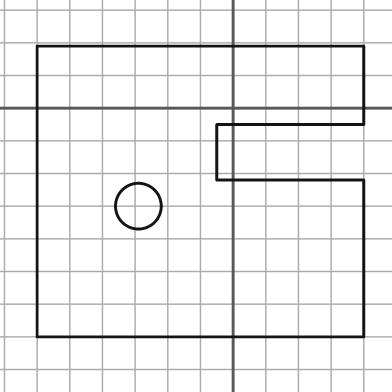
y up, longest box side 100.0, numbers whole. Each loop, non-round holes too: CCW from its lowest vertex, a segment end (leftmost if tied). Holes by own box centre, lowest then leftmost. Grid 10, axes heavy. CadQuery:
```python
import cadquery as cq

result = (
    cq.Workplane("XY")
    .moveTo(-60.0, -70.0)
    .lineTo(40.0, -70.0)
    .lineTo(40.0, -22.0)
    .lineTo(-5.0, -22.0)
    .lineTo(-5.0, -5.0)
    .lineTo(40.0, -5.0)
    .lineTo(40.0, 19.0)
    .lineTo(-60.0, 19.0)
    .close()
    .moveTo(-29.0, -30.0)
    .circle(7.0)
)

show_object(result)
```